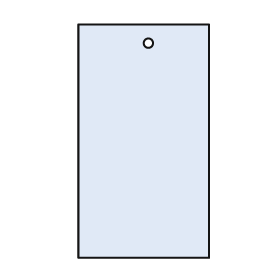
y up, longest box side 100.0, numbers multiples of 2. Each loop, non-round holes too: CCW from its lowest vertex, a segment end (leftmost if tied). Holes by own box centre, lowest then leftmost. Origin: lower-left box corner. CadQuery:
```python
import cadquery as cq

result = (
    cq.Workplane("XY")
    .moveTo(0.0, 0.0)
    .lineTo(56.0, 0.0)
    .lineTo(56.0, 100.0)
    .lineTo(0.0, 100.0)
    .close()
    .moveTo(30.0, 92.0)
    .circle(2.0)
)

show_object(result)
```